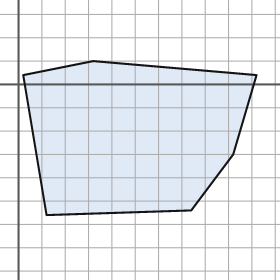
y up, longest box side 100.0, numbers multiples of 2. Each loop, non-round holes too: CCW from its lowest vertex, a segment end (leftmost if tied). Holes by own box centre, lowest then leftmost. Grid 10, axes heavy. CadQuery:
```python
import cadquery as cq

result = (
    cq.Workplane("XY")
    .moveTo(12.0, -56.0)
    .lineTo(74.0, -54.0)
    .lineTo(92.0, -30.0)
    .lineTo(102.0, 4.0)
    .lineTo(32.0, 10.0)
    .lineTo(2.0, 4.0)
    .close()
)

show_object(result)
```